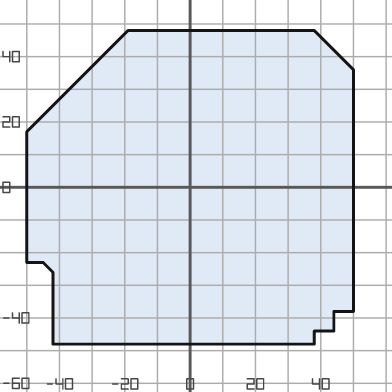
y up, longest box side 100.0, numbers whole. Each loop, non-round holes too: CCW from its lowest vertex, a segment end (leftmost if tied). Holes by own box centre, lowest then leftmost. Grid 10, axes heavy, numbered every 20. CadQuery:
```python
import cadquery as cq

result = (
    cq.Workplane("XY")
    .moveTo(-42.0, -48.0)
    .lineTo(38.0, -48.0)
    .lineTo(38.0, -44.0)
    .lineTo(44.0, -44.0)
    .lineTo(44.0, -38.0)
    .lineTo(50.0, -38.0)
    .lineTo(50.0, 36.0)
    .lineTo(38.0, 48.0)
    .lineTo(-19.0, 48.0)
    .lineTo(-50.0, 17.0)
    .lineTo(-50.0, -23.0)
    .lineTo(-45.0, -23.0)
    .lineTo(-42.0, -26.0)
    .close()
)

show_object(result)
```